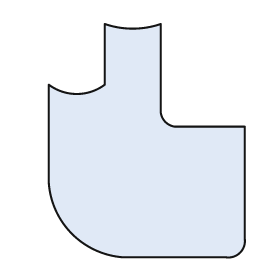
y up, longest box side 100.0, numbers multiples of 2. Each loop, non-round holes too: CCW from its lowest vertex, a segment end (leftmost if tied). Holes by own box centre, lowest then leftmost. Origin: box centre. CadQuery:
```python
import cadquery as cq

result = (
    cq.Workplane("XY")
    .moveTo(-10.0, -50.0)
    .lineTo(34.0, -50.0)
    .threePointArc((40.0, -48.0), (42.0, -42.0))
    .lineTo(42.0, 6.0)
    .lineTo(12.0, 6.0)
    .threePointArc((8.0, 8.0), (6.0, 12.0))
    .lineTo(6.0, 50.0)
    .threePointArc((-6.0, 48.0), (-18.0, 50.0))
    .lineTo(-18.0, 24.0)
    .threePointArc((-30.0, 20.0), (-42.0, 24.0))
    .lineTo(-42.0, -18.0)
    .threePointArc((-32.0, -40.0), (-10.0, -50.0))
    .close()
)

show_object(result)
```